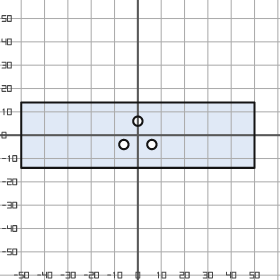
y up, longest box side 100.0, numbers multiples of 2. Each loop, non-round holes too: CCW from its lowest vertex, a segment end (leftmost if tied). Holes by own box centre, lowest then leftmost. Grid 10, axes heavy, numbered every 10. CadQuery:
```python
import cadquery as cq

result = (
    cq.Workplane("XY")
    .moveTo(-50.0, -14.0)
    .lineTo(50.0, -14.0)
    .lineTo(50.0, 14.0)
    .lineTo(-50.0, 14.0)
    .close()
    .moveTo(-6.0, -4.0)
    .circle(2.0)
    .moveTo(6.0, -4.0)
    .circle(2.0)
    .moveTo(0.0, 6.0)
    .circle(2.0)
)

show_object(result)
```